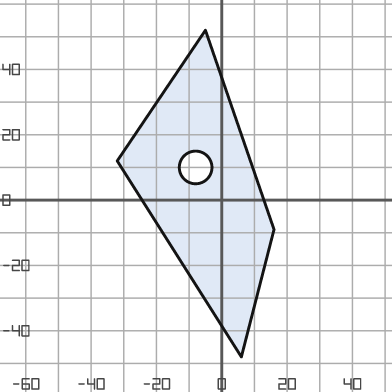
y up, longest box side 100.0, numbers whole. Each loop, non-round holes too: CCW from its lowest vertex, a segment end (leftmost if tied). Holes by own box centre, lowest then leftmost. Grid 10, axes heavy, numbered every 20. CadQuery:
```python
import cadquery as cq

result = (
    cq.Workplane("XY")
    .moveTo(6.0, -48.0)
    .lineTo(16.0, -9.0)
    .lineTo(-5.0, 52.0)
    .lineTo(-32.0, 12.0)
    .close()
    .moveTo(-8.0, 10.0)
    .circle(5.0)
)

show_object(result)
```